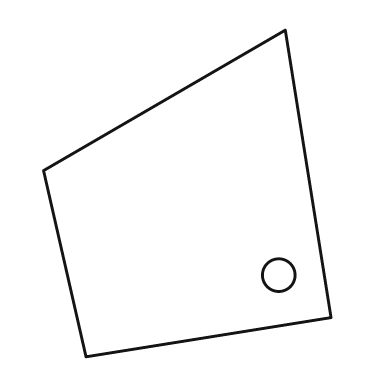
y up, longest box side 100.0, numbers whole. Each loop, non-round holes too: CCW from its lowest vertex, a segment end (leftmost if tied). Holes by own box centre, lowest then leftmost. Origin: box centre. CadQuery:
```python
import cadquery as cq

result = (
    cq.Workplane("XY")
    .moveTo(-31.0, -50.0)
    .lineTo(44.0, -38.0)
    .lineTo(30.0, 50.0)
    .lineTo(-44.0, 7.0)
    .close()
    .moveTo(28.0, -25.0)
    .circle(5.0)
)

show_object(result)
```